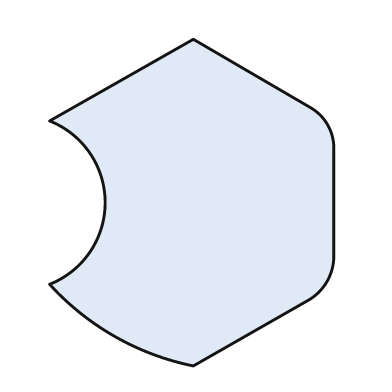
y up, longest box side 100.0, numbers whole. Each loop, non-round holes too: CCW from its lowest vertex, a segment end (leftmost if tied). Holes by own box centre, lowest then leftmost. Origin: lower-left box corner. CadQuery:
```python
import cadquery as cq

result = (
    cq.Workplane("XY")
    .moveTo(44.0, 0.0)
    .lineTo(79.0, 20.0)
    .threePointArc((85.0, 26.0), (87.0, 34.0))
    .lineTo(87.0, 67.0)
    .threePointArc((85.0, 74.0), (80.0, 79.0))
    .lineTo(44.0, 100.0)
    .lineTo(0.0, 75.0)
    .threePointArc((17.0, 50.0), (0.0, 25.0))
    .threePointArc((20.0, 9.0), (44.0, 0.0))
    .close()
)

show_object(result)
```